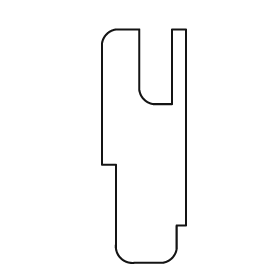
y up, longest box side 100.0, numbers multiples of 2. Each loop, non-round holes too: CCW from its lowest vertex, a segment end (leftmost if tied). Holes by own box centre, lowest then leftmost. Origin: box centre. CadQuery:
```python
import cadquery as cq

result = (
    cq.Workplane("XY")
    .moveTo(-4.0, -50.0)
    .lineTo(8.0, -50.0)
    .threePointArc((12.0, -48.0), (14.0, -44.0))
    .lineTo(14.0, -34.0)
    .lineTo(18.0, -34.0)
    .lineTo(18.0, 50.0)
    .lineTo(12.0, 50.0)
    .lineTo(12.0, 18.0)
    .lineTo(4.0, 18.0)
    .threePointArc((0.0, 20.0), (-2.0, 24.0))
    .lineTo(-2.0, 50.0)
    .lineTo(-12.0, 50.0)
    .threePointArc((-16.0, 48.0), (-18.0, 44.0))
    .lineTo(-18.0, -8.0)
    .lineTo(-12.0, -8.0)
    .lineTo(-12.0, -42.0)
    .threePointArc((-10.0, -48.0), (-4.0, -50.0))
    .close()
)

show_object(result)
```